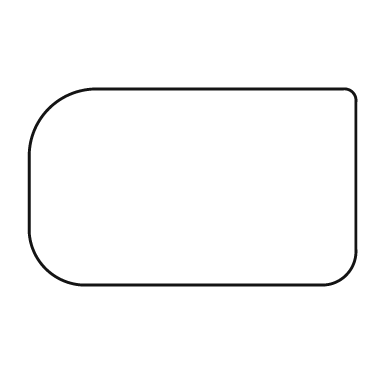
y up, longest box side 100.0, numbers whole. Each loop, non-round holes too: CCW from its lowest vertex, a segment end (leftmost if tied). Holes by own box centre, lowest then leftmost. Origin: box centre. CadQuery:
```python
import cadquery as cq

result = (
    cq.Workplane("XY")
    .moveTo(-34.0, -30.0)
    .lineTo(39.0, -30.0)
    .threePointArc((47.0, -27.0), (50.0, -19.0))
    .lineTo(50.0, 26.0)
    .threePointArc((49.0, 29.0), (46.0, 30.0))
    .lineTo(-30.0, 30.0)
    .threePointArc((-44.0, 24.0), (-50.0, 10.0))
    .lineTo(-50.0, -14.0)
    .threePointArc((-45.0, -25.0), (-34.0, -30.0))
    .close()
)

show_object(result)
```